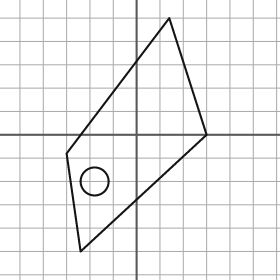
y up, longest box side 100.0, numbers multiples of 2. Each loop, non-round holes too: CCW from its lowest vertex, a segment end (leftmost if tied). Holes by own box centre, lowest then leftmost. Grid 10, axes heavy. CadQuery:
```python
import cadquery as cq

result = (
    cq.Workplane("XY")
    .moveTo(-24.0, -50.0)
    .lineTo(30.0, 0.0)
    .lineTo(14.0, 50.0)
    .lineTo(-30.0, -8.0)
    .close()
    .moveTo(-18.0, -20.0)
    .circle(6.0)
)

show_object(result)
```